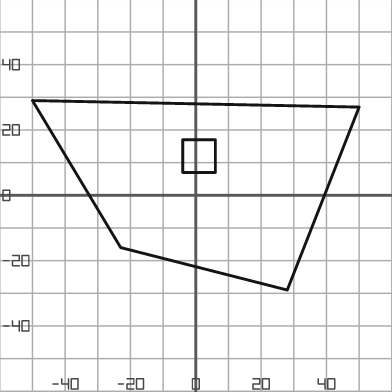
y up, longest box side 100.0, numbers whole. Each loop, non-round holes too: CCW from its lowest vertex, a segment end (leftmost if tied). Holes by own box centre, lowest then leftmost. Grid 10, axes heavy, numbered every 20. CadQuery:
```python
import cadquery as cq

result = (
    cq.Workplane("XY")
    .moveTo(28.0, -29.0)
    .lineTo(50.0, 27.0)
    .lineTo(-50.0, 29.0)
    .lineTo(-23.0, -16.0)
    .close()
    .moveTo(-4.0, 7.0)
    .lineTo(6.0, 7.0)
    .lineTo(6.0, 17.0)
    .lineTo(-4.0, 17.0)
    .close()
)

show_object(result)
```